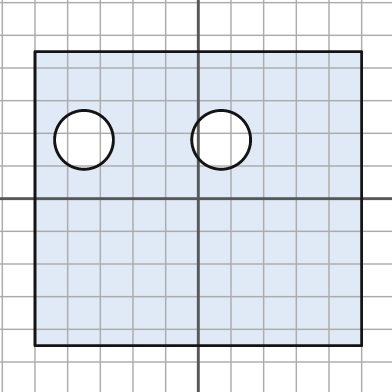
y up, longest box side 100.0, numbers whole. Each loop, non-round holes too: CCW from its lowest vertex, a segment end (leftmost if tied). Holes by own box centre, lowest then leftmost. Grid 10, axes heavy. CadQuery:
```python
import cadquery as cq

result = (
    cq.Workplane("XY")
    .moveTo(-50.0, -45.0)
    .lineTo(50.0, -45.0)
    .lineTo(50.0, 45.0)
    .lineTo(-50.0, 45.0)
    .close()
    .moveTo(-35.0, 18.0)
    .circle(9.0)
    .moveTo(7.0, 18.0)
    .circle(9.0)
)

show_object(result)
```